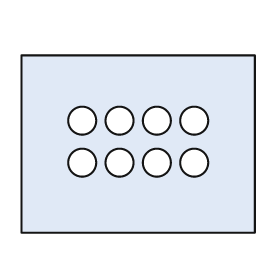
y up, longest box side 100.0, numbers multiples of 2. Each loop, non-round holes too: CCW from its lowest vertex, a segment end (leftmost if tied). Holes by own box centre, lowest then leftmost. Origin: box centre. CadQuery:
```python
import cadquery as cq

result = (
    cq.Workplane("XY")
    .moveTo(-50.0, -38.0)
    .lineTo(50.0, -38.0)
    .lineTo(50.0, 38.0)
    .lineTo(-50.0, 38.0)
    .close()
    .moveTo(-24.0, -8.0)
    .circle(6.0)
    .moveTo(-8.0, -8.0)
    .circle(6.0)
    .moveTo(8.0, -8.0)
    .circle(6.0)
    .moveTo(24.0, -8.0)
    .circle(6.0)
    .moveTo(-24.0, 10.0)
    .circle(6.0)
    .moveTo(-8.0, 10.0)
    .circle(6.0)
    .moveTo(8.0, 10.0)
    .circle(6.0)
    .moveTo(24.0, 10.0)
    .circle(6.0)
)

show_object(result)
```